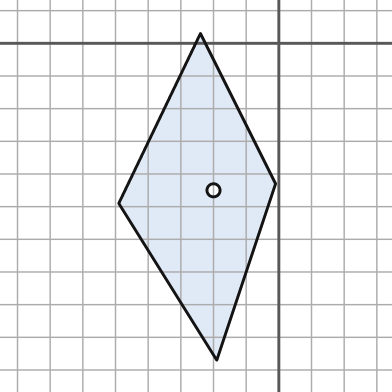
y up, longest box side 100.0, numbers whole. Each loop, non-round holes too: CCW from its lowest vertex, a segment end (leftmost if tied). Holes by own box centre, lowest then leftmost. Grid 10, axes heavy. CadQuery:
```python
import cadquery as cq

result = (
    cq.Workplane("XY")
    .moveTo(-19.0, -97.0)
    .lineTo(-1.0, -43.0)
    .lineTo(-24.0, 3.0)
    .lineTo(-49.0, -49.0)
    .close()
    .moveTo(-20.0, -45.0)
    .circle(2.0)
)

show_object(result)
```